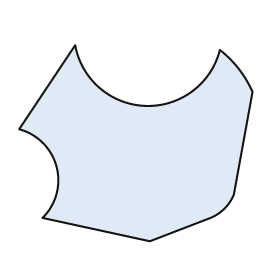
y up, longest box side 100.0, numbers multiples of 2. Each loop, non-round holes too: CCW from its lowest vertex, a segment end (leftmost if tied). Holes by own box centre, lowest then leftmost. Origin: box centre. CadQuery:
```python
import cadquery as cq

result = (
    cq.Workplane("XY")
    .moveTo(6.0, -42.0)
    .lineTo(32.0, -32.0)
    .threePointArc((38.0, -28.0), (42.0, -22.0))
    .lineTo(50.0, 22.0)
    .threePointArc((44.0, 32.0), (36.0, 40.0))
    .threePointArc((4.0, 16.0), (-26.0, 42.0))
    .lineTo(-50.0, 6.0)
    .threePointArc((-34.0, -10.0), (-40.0, -32.0))
    .close()
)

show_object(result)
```